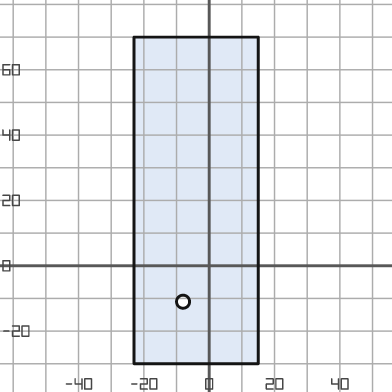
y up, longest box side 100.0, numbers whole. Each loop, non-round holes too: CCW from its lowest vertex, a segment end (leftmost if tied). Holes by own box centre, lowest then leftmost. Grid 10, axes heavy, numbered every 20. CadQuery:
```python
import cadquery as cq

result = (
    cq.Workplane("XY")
    .moveTo(-23.0, -30.0)
    .lineTo(15.0, -30.0)
    .lineTo(15.0, 70.0)
    .lineTo(-23.0, 70.0)
    .close()
    .moveTo(-8.0, -11.0)
    .circle(2.0)
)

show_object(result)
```